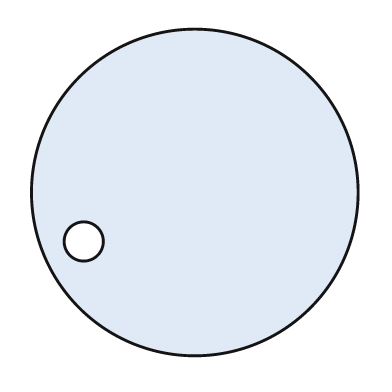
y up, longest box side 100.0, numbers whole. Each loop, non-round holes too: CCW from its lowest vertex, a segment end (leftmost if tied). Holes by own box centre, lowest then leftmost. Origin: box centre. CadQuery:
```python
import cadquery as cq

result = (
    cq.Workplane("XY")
    .moveTo(0.0, 0.0)
    .circle(50.0)
    .moveTo(-34.0, -15.0)
    .circle(6.0)
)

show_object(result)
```